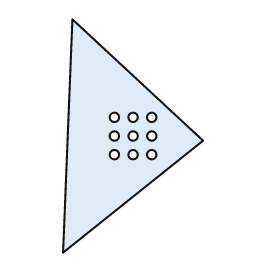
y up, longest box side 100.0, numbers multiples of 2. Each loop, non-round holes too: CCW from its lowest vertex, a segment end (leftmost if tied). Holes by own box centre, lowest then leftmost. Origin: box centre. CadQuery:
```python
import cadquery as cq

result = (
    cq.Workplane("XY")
    .moveTo(-30.0, -50.0)
    .lineTo(30.0, -2.0)
    .lineTo(-26.0, 50.0)
    .close()
    .moveTo(-8.0, -8.0)
    .circle(2.0)
    .moveTo(0.0, -8.0)
    .circle(2.0)
    .moveTo(8.0, -8.0)
    .circle(2.0)
    .moveTo(-8.0, 0.0)
    .circle(2.0)
    .moveTo(0.0, 0.0)
    .circle(2.0)
    .moveTo(8.0, 0.0)
    .circle(2.0)
    .moveTo(-8.0, 8.0)
    .circle(2.0)
    .moveTo(0.0, 8.0)
    .circle(2.0)
    .moveTo(8.0, 8.0)
    .circle(2.0)
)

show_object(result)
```